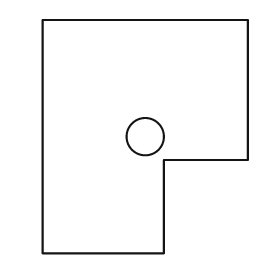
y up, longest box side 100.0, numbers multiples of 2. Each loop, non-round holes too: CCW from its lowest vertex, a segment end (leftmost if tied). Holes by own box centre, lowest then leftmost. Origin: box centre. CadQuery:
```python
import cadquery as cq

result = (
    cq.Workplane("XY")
    .moveTo(-44.0, -50.0)
    .lineTo(8.0, -50.0)
    .lineTo(8.0, -10.0)
    .lineTo(44.0, -10.0)
    .lineTo(44.0, 50.0)
    .lineTo(-44.0, 50.0)
    .close()
    .moveTo(0.0, 0.0)
    .circle(8.0)
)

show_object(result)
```